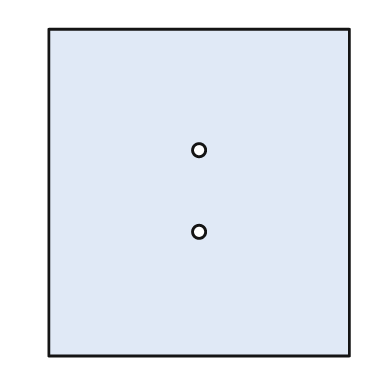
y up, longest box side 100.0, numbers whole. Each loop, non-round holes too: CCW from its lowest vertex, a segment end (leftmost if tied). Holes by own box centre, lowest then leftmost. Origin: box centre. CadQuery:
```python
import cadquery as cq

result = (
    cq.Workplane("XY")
    .moveTo(-46.0, -50.0)
    .lineTo(46.0, -50.0)
    .lineTo(46.0, 50.0)
    .lineTo(-46.0, 50.0)
    .close()
    .moveTo(0.0, -12.0)
    .circle(2.0)
    .moveTo(0.0, 13.0)
    .circle(2.0)
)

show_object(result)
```